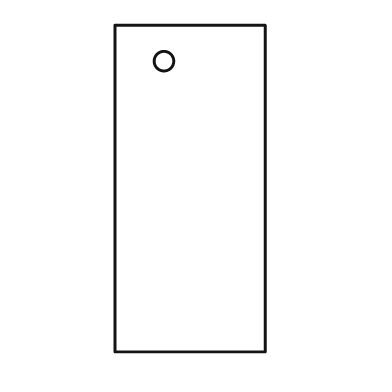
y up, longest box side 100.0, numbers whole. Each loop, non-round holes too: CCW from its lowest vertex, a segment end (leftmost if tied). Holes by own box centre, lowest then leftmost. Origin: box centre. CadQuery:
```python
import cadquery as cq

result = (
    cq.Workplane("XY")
    .moveTo(-23.0, -50.0)
    .lineTo(23.0, -50.0)
    .lineTo(23.0, 50.0)
    .lineTo(-23.0, 50.0)
    .close()
    .moveTo(-8.0, 39.0)
    .circle(3.0)
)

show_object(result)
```